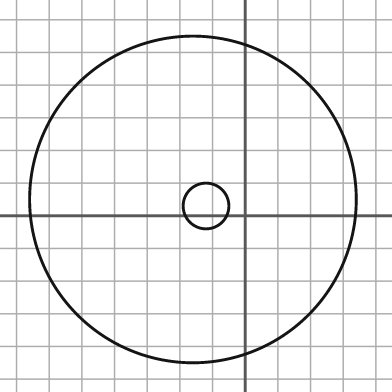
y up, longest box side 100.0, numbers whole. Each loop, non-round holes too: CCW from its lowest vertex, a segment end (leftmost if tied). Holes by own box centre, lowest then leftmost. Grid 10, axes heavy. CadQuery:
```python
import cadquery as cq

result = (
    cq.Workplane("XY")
    .moveTo(-16.0, 5.0)
    .circle(50.0)
    .moveTo(-12.0, 3.0)
    .circle(7.0)
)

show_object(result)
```